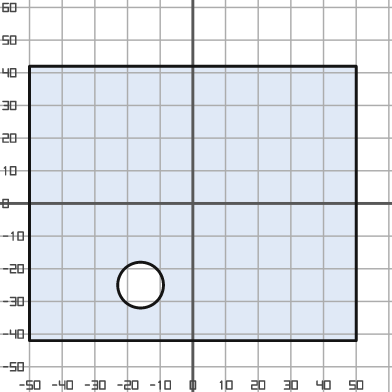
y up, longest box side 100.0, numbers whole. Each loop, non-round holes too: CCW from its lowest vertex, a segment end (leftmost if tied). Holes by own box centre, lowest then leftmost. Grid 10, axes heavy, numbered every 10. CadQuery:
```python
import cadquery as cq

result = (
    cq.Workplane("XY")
    .moveTo(-50.0, -42.0)
    .lineTo(50.0, -42.0)
    .lineTo(50.0, 42.0)
    .lineTo(-50.0, 42.0)
    .close()
    .moveTo(-16.0, -25.0)
    .circle(7.0)
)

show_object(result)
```